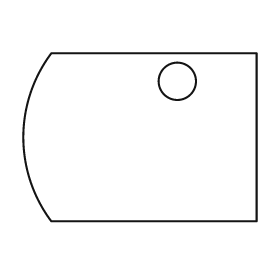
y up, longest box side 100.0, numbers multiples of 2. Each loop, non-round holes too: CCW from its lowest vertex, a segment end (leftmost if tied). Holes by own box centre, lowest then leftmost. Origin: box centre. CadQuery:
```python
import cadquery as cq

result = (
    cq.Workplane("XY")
    .moveTo(-38.0, -36.0)
    .lineTo(50.0, -36.0)
    .lineTo(50.0, 36.0)
    .lineTo(-38.0, 36.0)
    .threePointArc((-50.0, 0.0), (-38.0, -36.0))
    .close()
    .moveTo(16.0, 24.0)
    .circle(8.0)
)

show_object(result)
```